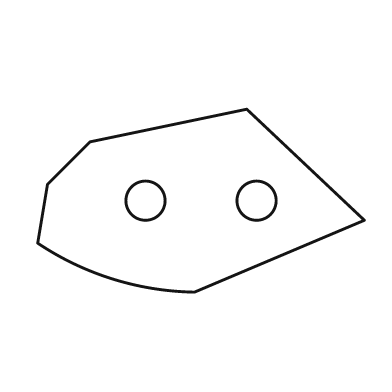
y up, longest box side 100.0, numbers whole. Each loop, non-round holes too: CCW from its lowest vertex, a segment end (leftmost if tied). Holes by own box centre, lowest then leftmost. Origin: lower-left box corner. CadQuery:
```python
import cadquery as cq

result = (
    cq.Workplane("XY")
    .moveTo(48.0, 0.0)
    .lineTo(100.0, 22.0)
    .lineTo(64.0, 56.0)
    .lineTo(16.0, 46.0)
    .lineTo(3.0, 33.0)
    .lineTo(0.0, 15.0)
    .threePointArc((23.0, 4.0), (48.0, 0.0))
    .close()
    .moveTo(33.0, 28.0)
    .circle(6.0)
    .moveTo(67.0, 28.0)
    .circle(6.0)
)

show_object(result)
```